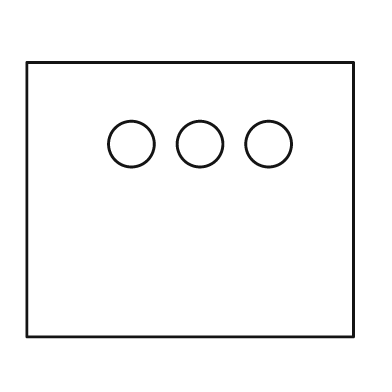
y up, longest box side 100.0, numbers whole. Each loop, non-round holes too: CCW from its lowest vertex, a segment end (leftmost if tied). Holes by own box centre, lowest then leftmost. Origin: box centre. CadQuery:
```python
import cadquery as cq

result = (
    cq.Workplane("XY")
    .moveTo(-50.0, -42.0)
    .lineTo(50.0, -42.0)
    .lineTo(50.0, 42.0)
    .lineTo(-50.0, 42.0)
    .close()
    .moveTo(-18.0, 17.0)
    .circle(7.0)
    .moveTo(3.0, 17.0)
    .circle(7.0)
    .moveTo(24.0, 17.0)
    .circle(7.0)
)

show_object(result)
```